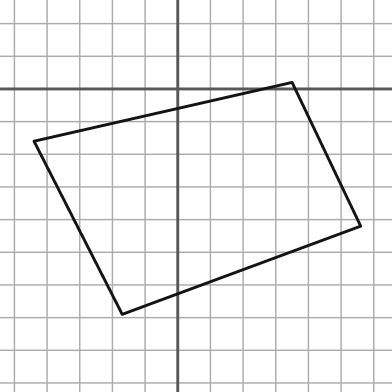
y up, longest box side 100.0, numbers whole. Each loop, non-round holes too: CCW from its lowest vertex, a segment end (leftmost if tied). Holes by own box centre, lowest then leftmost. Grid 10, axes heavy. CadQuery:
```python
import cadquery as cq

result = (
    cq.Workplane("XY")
    .moveTo(-17.0, -69.0)
    .lineTo(56.0, -42.0)
    .lineTo(35.0, 2.0)
    .lineTo(-44.0, -16.0)
    .close()
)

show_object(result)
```